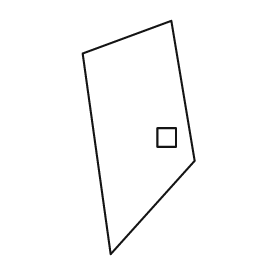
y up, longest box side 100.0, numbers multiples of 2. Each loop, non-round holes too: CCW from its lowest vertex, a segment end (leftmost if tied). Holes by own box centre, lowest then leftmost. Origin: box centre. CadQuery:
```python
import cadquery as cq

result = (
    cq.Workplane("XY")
    .moveTo(-12.0, -50.0)
    .lineTo(24.0, -10.0)
    .lineTo(14.0, 50.0)
    .lineTo(-24.0, 36.0)
    .close()
    .moveTo(8.0, -4.0)
    .lineTo(16.0, -4.0)
    .lineTo(16.0, 4.0)
    .lineTo(8.0, 4.0)
    .close()
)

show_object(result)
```